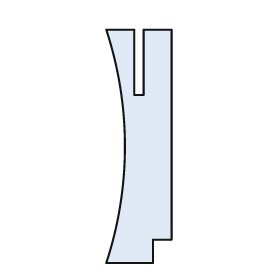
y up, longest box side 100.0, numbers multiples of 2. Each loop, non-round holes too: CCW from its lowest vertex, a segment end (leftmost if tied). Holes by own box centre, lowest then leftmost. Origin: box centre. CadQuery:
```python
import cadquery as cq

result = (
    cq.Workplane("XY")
    .moveTo(-14.0, -50.0)
    .lineTo(6.0, -50.0)
    .lineTo(6.0, -40.0)
    .lineTo(14.0, -40.0)
    .lineTo(14.0, 50.0)
    .lineTo(2.0, 50.0)
    .lineTo(2.0, 22.0)
    .lineTo(-2.0, 22.0)
    .lineTo(-2.0, 50.0)
    .lineTo(-14.0, 50.0)
    .threePointArc((-6.0, 0.0), (-14.0, -50.0))
    .close()
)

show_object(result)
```